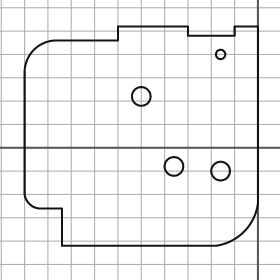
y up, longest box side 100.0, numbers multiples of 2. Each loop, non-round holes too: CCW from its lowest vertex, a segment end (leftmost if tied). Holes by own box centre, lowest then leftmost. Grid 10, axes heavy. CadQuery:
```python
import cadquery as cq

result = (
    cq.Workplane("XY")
    .moveTo(-84.0, -42.0)
    .lineTo(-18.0, -42.0)
    .threePointArc((-6.0, -36.0), (0.0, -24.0))
    .lineTo(0.0, 52.0)
    .lineTo(-10.0, 52.0)
    .lineTo(-10.0, 48.0)
    .lineTo(-30.0, 48.0)
    .lineTo(-30.0, 52.0)
    .lineTo(-60.0, 52.0)
    .lineTo(-60.0, 46.0)
    .lineTo(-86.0, 46.0)
    .threePointArc((-96.0, 42.0), (-100.0, 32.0))
    .lineTo(-100.0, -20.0)
    .threePointArc((-98.0, -24.0), (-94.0, -26.0))
    .lineTo(-84.0, -26.0)
    .close()
    .moveTo(-16.0, -10.0)
    .circle(4.0)
    .moveTo(-36.0, -8.0)
    .circle(4.0)
    .moveTo(-50.0, 22.0)
    .circle(4.0)
    .moveTo(-16.0, 40.0)
    .circle(2.0)
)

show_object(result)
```